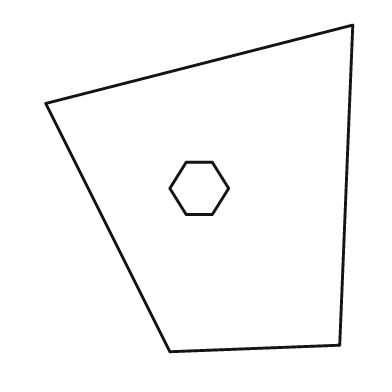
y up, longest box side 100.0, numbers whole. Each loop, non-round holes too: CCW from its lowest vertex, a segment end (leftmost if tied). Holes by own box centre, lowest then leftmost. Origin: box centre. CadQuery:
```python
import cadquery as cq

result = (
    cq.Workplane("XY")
    .moveTo(-9.0, -50.0)
    .lineTo(43.0, -48.0)
    .lineTo(47.0, 50.0)
    .lineTo(-47.0, 26.0)
    .close()
    .moveTo(-4.0, -8.0)
    .lineTo(4.0, -8.0)
    .lineTo(9.0, 0.0)
    .lineTo(4.0, 8.0)
    .lineTo(-4.0, 8.0)
    .lineTo(-9.0, 0.0)
    .close()
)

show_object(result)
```